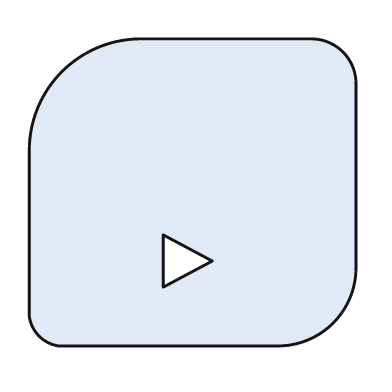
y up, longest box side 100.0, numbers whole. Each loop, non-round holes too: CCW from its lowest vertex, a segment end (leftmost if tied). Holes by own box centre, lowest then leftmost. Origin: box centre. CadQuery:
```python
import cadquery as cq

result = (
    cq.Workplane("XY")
    .moveTo(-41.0, -47.0)
    .lineTo(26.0, -47.0)
    .threePointArc((43.0, -40.0), (50.0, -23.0))
    .lineTo(50.0, 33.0)
    .threePointArc((46.0, 43.0), (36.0, 47.0))
    .lineTo(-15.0, 47.0)
    .threePointArc((-40.0, 37.0), (-50.0, 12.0))
    .lineTo(-50.0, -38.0)
    .threePointArc((-47.0, -44.0), (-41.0, -47.0))
    .close()
    .moveTo(-9.0, -29.0)
    .lineTo(6.0, -21.0)
    .lineTo(-9.0, -13.0)
    .close()
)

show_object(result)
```